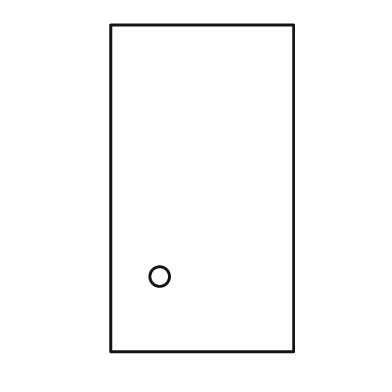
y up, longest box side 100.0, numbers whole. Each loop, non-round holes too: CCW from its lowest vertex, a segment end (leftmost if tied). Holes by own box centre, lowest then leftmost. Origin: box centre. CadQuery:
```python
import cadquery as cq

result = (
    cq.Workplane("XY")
    .moveTo(-28.0, -50.0)
    .lineTo(28.0, -50.0)
    .lineTo(28.0, 50.0)
    .lineTo(-28.0, 50.0)
    .close()
    .moveTo(-13.0, -27.0)
    .circle(3.0)
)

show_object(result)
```